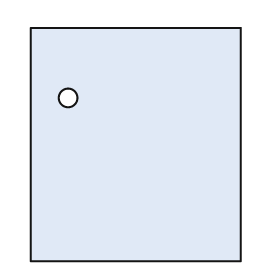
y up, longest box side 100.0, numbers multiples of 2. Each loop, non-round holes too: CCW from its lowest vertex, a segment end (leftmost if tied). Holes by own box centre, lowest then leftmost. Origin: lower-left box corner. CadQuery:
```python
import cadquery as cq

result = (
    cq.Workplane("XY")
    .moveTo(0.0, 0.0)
    .lineTo(90.0, 0.0)
    .lineTo(90.0, 100.0)
    .lineTo(0.0, 100.0)
    .close()
    .moveTo(16.0, 70.0)
    .circle(4.0)
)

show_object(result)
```